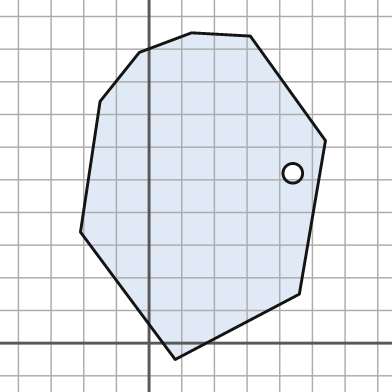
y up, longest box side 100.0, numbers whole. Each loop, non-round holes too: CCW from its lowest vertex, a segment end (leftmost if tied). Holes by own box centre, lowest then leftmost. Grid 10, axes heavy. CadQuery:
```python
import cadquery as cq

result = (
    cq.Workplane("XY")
    .moveTo(8.0, -5.0)
    .lineTo(46.0, 15.0)
    .lineTo(54.0, 62.0)
    .lineTo(31.0, 94.0)
    .lineTo(13.0, 95.0)
    .lineTo(-3.0, 89.0)
    .lineTo(-15.0, 74.0)
    .lineTo(-21.0, 34.0)
    .close()
    .moveTo(44.0, 52.0)
    .circle(3.0)
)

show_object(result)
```